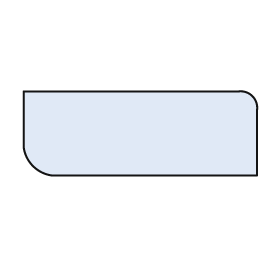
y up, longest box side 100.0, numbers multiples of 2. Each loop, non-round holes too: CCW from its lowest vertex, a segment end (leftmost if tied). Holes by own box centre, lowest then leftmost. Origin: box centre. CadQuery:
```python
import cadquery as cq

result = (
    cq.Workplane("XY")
    .moveTo(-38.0, -18.0)
    .lineTo(50.0, -18.0)
    .lineTo(50.0, 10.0)
    .threePointArc((48.0, 16.0), (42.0, 18.0))
    .lineTo(-50.0, 18.0)
    .lineTo(-50.0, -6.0)
    .threePointArc((-46.0, -14.0), (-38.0, -18.0))
    .close()
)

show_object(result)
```